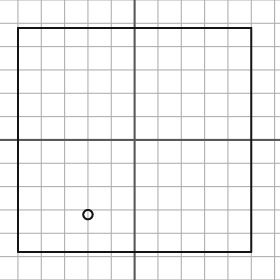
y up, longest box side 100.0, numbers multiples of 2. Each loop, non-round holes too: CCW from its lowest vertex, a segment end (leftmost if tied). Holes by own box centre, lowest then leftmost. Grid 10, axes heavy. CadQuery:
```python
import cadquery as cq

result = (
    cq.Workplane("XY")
    .moveTo(-50.0, -48.0)
    .lineTo(50.0, -48.0)
    .lineTo(50.0, 48.0)
    .lineTo(-50.0, 48.0)
    .close()
    .moveTo(-20.0, -32.0)
    .circle(2.0)
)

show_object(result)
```